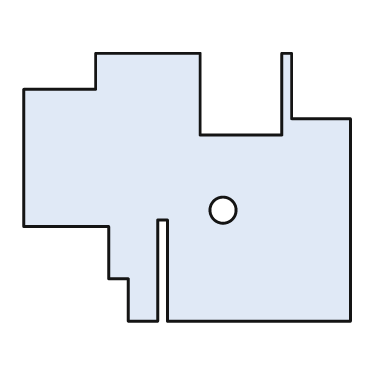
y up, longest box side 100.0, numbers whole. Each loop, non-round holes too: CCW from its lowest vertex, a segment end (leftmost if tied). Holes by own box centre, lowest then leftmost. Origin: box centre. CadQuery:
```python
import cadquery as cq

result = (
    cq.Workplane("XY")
    .moveTo(-18.0, -41.0)
    .lineTo(-9.0, -41.0)
    .lineTo(-9.0, -10.0)
    .lineTo(-6.0, -10.0)
    .lineTo(-6.0, -41.0)
    .lineTo(50.0, -41.0)
    .lineTo(50.0, 21.0)
    .lineTo(32.0, 21.0)
    .lineTo(32.0, 41.0)
    .lineTo(29.0, 41.0)
    .lineTo(29.0, 16.0)
    .lineTo(4.0, 16.0)
    .lineTo(4.0, 41.0)
    .lineTo(-28.0, 41.0)
    .lineTo(-28.0, 30.0)
    .lineTo(-50.0, 30.0)
    .lineTo(-50.0, -12.0)
    .lineTo(-24.0, -12.0)
    .lineTo(-24.0, -28.0)
    .lineTo(-18.0, -28.0)
    .close()
    .moveTo(11.0, -7.0)
    .circle(4.0)
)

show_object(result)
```